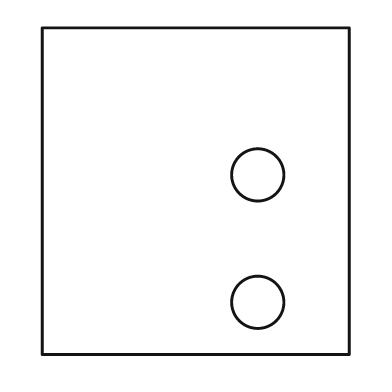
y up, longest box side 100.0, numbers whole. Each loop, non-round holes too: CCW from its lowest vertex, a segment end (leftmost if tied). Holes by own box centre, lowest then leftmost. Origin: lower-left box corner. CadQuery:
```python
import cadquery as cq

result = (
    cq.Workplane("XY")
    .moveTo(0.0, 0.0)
    .lineTo(94.0, 0.0)
    .lineTo(94.0, 100.0)
    .lineTo(0.0, 100.0)
    .close()
    .moveTo(66.0, 16.0)
    .circle(8.0)
    .moveTo(66.0, 55.0)
    .circle(8.0)
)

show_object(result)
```